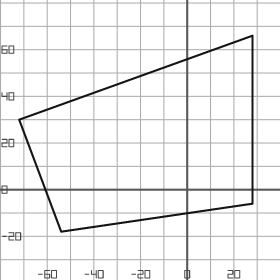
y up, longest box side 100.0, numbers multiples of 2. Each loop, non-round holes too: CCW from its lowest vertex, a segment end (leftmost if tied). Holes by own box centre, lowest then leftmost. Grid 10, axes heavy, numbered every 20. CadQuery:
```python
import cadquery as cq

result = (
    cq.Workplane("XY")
    .moveTo(-54.0, -18.0)
    .lineTo(28.0, -6.0)
    .lineTo(28.0, 66.0)
    .lineTo(-72.0, 30.0)
    .close()
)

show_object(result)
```